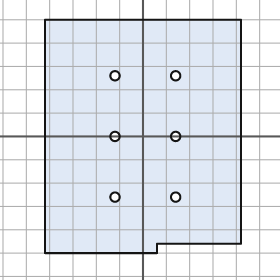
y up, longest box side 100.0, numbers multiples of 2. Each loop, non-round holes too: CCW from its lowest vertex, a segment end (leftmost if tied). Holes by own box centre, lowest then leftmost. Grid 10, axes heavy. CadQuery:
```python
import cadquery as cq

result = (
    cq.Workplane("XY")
    .moveTo(-42.0, -50.0)
    .lineTo(6.0, -50.0)
    .lineTo(6.0, -46.0)
    .lineTo(42.0, -46.0)
    .lineTo(42.0, 50.0)
    .lineTo(-42.0, 50.0)
    .close()
    .moveTo(-12.0, -26.0)
    .circle(2.0)
    .moveTo(14.0, -26.0)
    .circle(2.0)
    .moveTo(-12.0, 0.0)
    .circle(2.0)
    .moveTo(14.0, 0.0)
    .circle(2.0)
    .moveTo(-12.0, 26.0)
    .circle(2.0)
    .moveTo(14.0, 26.0)
    .circle(2.0)
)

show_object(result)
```